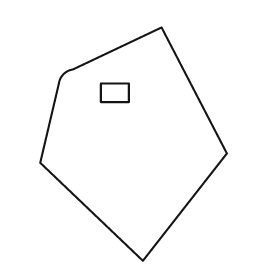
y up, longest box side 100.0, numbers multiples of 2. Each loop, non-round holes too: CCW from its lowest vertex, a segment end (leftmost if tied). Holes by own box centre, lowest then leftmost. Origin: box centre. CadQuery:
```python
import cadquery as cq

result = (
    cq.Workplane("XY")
    .moveTo(4.0, -50.0)
    .lineTo(40.0, -4.0)
    .lineTo(12.0, 50.0)
    .lineTo(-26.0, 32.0)
    .threePointArc((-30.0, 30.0), (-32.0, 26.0))
    .lineTo(-40.0, -8.0)
    .close()
    .moveTo(-14.0, 18.0)
    .lineTo(-2.0, 18.0)
    .lineTo(-2.0, 26.0)
    .lineTo(-14.0, 26.0)
    .close()
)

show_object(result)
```